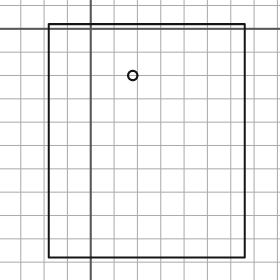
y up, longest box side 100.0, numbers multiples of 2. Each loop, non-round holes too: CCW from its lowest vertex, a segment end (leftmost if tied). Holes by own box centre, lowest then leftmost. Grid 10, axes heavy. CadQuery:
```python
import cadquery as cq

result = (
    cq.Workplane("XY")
    .moveTo(-18.0, -98.0)
    .lineTo(66.0, -98.0)
    .lineTo(66.0, 2.0)
    .lineTo(-18.0, 2.0)
    .close()
    .moveTo(18.0, -20.0)
    .circle(2.0)
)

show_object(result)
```